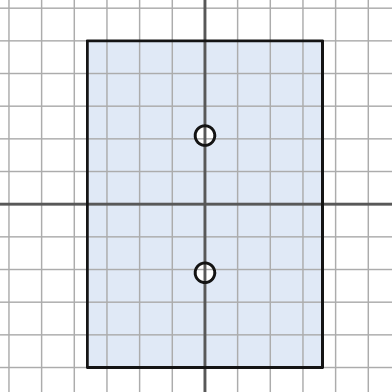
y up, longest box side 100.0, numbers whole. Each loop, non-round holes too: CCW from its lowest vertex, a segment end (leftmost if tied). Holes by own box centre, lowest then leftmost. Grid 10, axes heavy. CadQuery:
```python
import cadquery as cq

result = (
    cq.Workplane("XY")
    .moveTo(-36.0, -50.0)
    .lineTo(36.0, -50.0)
    .lineTo(36.0, 50.0)
    .lineTo(-36.0, 50.0)
    .close()
    .moveTo(0.0, -21.0)
    .circle(3.0)
    .moveTo(0.0, 21.0)
    .circle(3.0)
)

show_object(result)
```